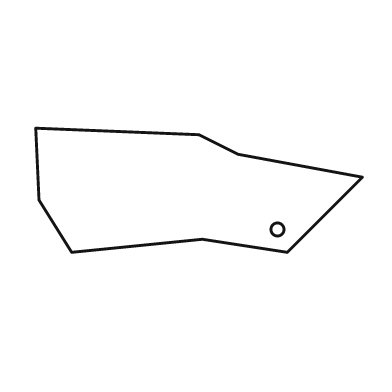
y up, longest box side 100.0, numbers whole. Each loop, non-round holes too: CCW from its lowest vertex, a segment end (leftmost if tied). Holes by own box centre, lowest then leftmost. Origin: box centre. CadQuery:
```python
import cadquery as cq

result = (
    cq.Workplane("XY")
    .moveTo(-39.0, -19.0)
    .lineTo(1.0, -15.0)
    .lineTo(27.0, -19.0)
    .lineTo(50.0, 4.0)
    .lineTo(12.0, 11.0)
    .lineTo(0.0, 17.0)
    .lineTo(-50.0, 19.0)
    .lineTo(-49.0, -3.0)
    .close()
    .moveTo(24.0, -12.0)
    .circle(2.0)
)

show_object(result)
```